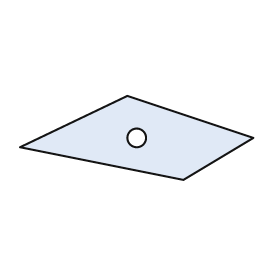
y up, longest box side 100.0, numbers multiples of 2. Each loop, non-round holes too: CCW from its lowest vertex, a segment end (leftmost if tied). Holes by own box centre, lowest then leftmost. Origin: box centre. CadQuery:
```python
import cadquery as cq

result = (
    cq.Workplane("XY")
    .moveTo(20.0, -18.0)
    .lineTo(50.0, 0.0)
    .lineTo(-4.0, 18.0)
    .lineTo(-50.0, -4.0)
    .close()
    .moveTo(0.0, 0.0)
    .circle(4.0)
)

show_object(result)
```